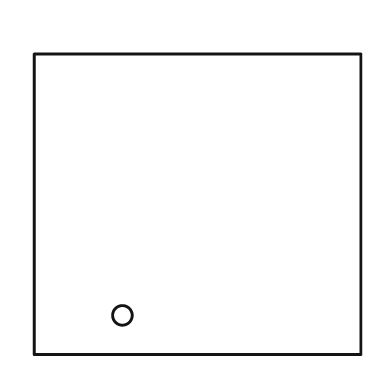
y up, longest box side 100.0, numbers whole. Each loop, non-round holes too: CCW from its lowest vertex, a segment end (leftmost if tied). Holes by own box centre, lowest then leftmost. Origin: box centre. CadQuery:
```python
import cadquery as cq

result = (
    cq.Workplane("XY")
    .moveTo(-50.0, -46.0)
    .lineTo(50.0, -46.0)
    .lineTo(50.0, 46.0)
    .lineTo(-50.0, 46.0)
    .close()
    .moveTo(-23.0, -34.0)
    .circle(3.0)
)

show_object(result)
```